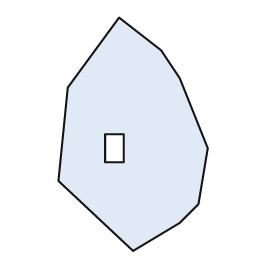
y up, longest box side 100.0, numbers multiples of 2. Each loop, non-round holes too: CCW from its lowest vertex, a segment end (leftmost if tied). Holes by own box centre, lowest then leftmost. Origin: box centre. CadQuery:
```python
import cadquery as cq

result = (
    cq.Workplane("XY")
    .moveTo(0.0, -50.0)
    .lineTo(20.0, -38.0)
    .lineTo(28.0, -30.0)
    .lineTo(32.0, -6.0)
    .lineTo(20.0, 24.0)
    .lineTo(12.0, 36.0)
    .lineTo(-6.0, 50.0)
    .lineTo(-28.0, 20.0)
    .lineTo(-32.0, -20.0)
    .close()
    .moveTo(-12.0, -12.0)
    .lineTo(-4.0, -12.0)
    .lineTo(-4.0, 0.0)
    .lineTo(-12.0, 0.0)
    .close()
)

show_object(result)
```